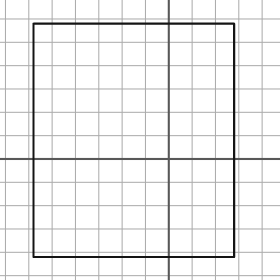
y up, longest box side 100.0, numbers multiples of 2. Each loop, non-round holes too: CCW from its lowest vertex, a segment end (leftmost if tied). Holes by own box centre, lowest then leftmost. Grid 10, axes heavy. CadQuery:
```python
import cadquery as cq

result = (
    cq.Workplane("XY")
    .moveTo(-58.0, -42.0)
    .lineTo(28.0, -42.0)
    .lineTo(28.0, 58.0)
    .lineTo(-58.0, 58.0)
    .close()
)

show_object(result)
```